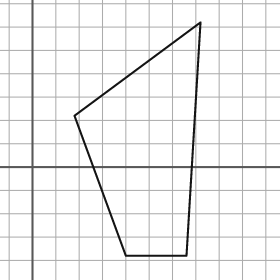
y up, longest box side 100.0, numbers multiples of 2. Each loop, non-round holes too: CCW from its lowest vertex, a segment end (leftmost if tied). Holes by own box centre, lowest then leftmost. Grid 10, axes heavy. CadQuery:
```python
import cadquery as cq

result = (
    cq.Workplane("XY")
    .moveTo(40.0, -38.0)
    .lineTo(66.0, -38.0)
    .lineTo(72.0, 62.0)
    .lineTo(18.0, 22.0)
    .close()
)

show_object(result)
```